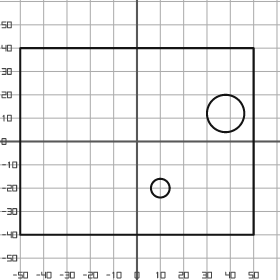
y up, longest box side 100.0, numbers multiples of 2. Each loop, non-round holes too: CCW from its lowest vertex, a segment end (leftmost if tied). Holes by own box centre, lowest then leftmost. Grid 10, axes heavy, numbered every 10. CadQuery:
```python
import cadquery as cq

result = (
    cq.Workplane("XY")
    .moveTo(-50.0, -40.0)
    .lineTo(50.0, -40.0)
    .lineTo(50.0, 40.0)
    .lineTo(-50.0, 40.0)
    .close()
    .moveTo(10.0, -20.0)
    .circle(4.0)
    .moveTo(38.0, 12.0)
    .circle(8.0)
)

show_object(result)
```